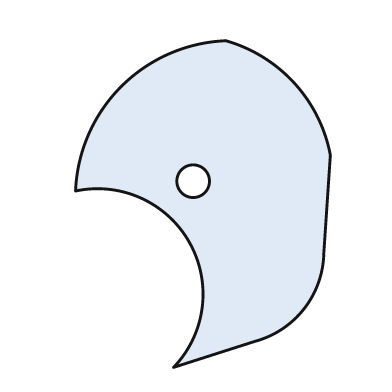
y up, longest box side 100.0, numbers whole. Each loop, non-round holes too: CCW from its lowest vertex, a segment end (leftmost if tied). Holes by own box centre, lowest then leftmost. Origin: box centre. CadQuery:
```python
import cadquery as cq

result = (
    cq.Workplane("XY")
    .moveTo(-9.0, -50.0)
    .lineTo(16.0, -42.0)
    .threePointArc((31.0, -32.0), (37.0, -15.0))
    .lineTo(39.0, 15.0)
    .threePointArc((28.0, 37.0), (7.0, 50.0))
    .threePointArc((-25.0, 36.0), (-39.0, 4.0))
    .threePointArc((-4.0, -12.0), (-9.0, -50.0))
    .close()
    .moveTo(-3.0, 7.0)
    .circle(5.0)
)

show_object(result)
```